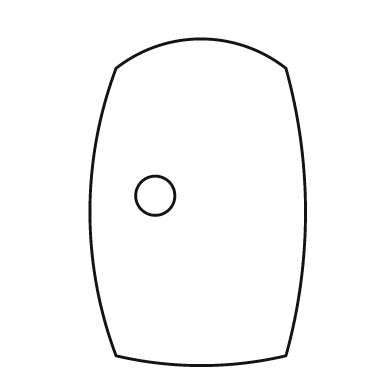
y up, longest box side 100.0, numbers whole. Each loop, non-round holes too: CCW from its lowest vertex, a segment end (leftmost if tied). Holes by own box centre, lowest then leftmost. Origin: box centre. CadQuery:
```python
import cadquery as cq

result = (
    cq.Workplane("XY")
    .moveTo(-25.0, -47.0)
    .threePointArc((1.0, -50.0), (27.0, -47.0))
    .threePointArc((33.0, -3.0), (27.0, 41.0))
    .threePointArc((1.0, 50.0), (-25.0, 41.0))
    .threePointArc((-33.0, -3.0), (-25.0, -47.0))
    .close()
    .moveTo(-13.0, 2.0)
    .circle(6.0)
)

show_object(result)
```